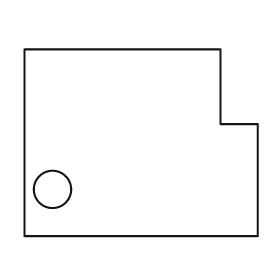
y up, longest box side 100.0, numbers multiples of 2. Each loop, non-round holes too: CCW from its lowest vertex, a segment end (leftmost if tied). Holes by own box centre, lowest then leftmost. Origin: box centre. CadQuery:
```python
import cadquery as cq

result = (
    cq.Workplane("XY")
    .moveTo(-50.0, -40.0)
    .lineTo(50.0, -40.0)
    .lineTo(50.0, 8.0)
    .lineTo(34.0, 8.0)
    .lineTo(34.0, 40.0)
    .lineTo(-50.0, 40.0)
    .close()
    .moveTo(-38.0, -20.0)
    .circle(8.0)
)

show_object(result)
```